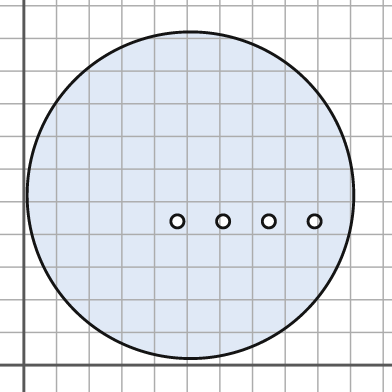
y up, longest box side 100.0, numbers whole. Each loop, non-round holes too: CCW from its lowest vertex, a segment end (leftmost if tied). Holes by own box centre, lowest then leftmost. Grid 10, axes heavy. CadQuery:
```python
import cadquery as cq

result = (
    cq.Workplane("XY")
    .moveTo(51.0, 52.0)
    .circle(50.0)
    .moveTo(47.0, 44.0)
    .circle(2.0)
    .moveTo(61.0, 44.0)
    .circle(2.0)
    .moveTo(75.0, 44.0)
    .circle(2.0)
    .moveTo(89.0, 44.0)
    .circle(2.0)
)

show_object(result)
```